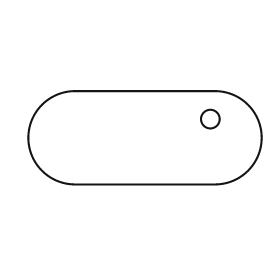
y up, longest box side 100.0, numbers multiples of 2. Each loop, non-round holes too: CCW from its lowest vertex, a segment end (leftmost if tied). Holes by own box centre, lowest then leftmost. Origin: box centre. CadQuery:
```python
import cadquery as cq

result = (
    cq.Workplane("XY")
    .moveTo(-30.0, -20.0)
    .lineTo(30.0, -20.0)
    .threePointArc((50.0, 0.0), (30.0, 20.0))
    .lineTo(-30.0, 20.0)
    .threePointArc((-50.0, 0.0), (-30.0, -20.0))
    .close()
    .moveTo(28.0, 8.0)
    .circle(4.0)
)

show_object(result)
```